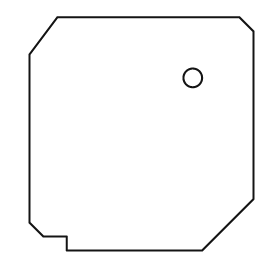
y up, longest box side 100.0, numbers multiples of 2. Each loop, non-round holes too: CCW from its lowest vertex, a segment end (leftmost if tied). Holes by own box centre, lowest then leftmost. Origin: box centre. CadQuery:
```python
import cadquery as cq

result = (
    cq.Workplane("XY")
    .moveTo(-32.0, -50.0)
    .lineTo(26.0, -50.0)
    .lineTo(48.0, -28.0)
    .lineTo(48.0, 44.0)
    .lineTo(42.0, 50.0)
    .lineTo(-36.0, 50.0)
    .lineTo(-48.0, 34.0)
    .lineTo(-48.0, -38.0)
    .lineTo(-42.0, -44.0)
    .lineTo(-32.0, -44.0)
    .close()
    .moveTo(22.0, 24.0)
    .circle(4.0)
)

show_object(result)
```